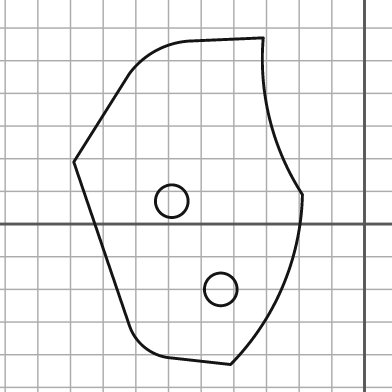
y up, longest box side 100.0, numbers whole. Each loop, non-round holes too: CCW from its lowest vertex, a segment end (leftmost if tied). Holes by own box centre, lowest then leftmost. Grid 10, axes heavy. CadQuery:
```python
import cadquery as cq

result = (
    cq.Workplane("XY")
    .moveTo(-41.0, -43.0)
    .threePointArc((-25.0, -19.0), (-19.0, 9.0))
    .threePointArc((-29.0, 32.0), (-31.0, 57.0))
    .lineTo(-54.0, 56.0)
    .threePointArc((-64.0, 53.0), (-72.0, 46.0))
    .lineTo(-89.0, 19.0)
    .lineTo(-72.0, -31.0)
    .threePointArc((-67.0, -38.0), (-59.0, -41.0))
    .close()
    .moveTo(-44.0, -20.0)
    .circle(5.0)
    .moveTo(-59.0, 7.0)
    .circle(5.0)
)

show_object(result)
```